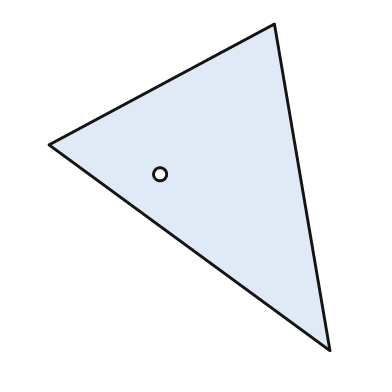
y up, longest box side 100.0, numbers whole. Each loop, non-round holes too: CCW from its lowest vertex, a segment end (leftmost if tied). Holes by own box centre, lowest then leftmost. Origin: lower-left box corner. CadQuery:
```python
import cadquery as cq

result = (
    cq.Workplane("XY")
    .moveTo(86.0, 0.0)
    .lineTo(69.0, 100.0)
    .lineTo(0.0, 63.0)
    .close()
    .moveTo(34.0, 54.0)
    .circle(2.0)
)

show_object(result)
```